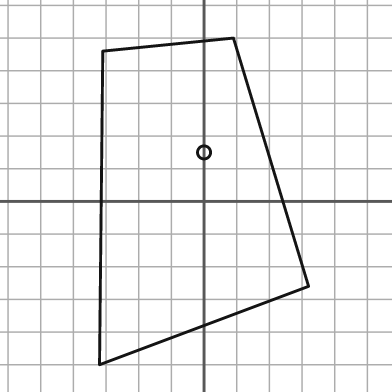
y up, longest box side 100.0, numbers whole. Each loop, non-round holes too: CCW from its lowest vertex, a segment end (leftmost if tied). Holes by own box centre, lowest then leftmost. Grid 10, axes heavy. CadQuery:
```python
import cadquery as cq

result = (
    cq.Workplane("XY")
    .moveTo(-32.0, -50.0)
    .lineTo(32.0, -26.0)
    .lineTo(9.0, 50.0)
    .lineTo(-31.0, 46.0)
    .close()
    .moveTo(0.0, 15.0)
    .circle(2.0)
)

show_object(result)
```